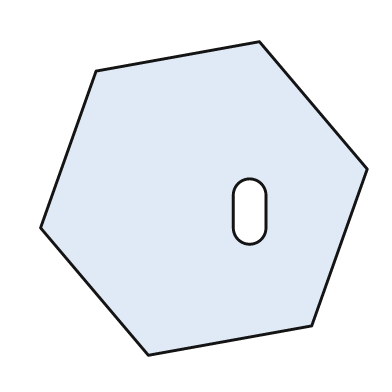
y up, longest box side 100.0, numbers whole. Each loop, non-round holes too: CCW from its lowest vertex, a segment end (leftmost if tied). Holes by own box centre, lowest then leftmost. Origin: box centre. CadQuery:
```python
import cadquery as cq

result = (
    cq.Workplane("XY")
    .moveTo(-17.0, -48.0)
    .lineTo(33.0, -39.0)
    .lineTo(50.0, 9.0)
    .lineTo(17.0, 48.0)
    .lineTo(-33.0, 39.0)
    .lineTo(-50.0, -9.0)
    .close()
    .moveTo(9.0, -9.0)
    .threePointArc((14.0, -14.0), (19.0, -9.0))
    .lineTo(19.0, 1.0)
    .threePointArc((14.0, 6.0), (9.0, 1.0))
    .close()
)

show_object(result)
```